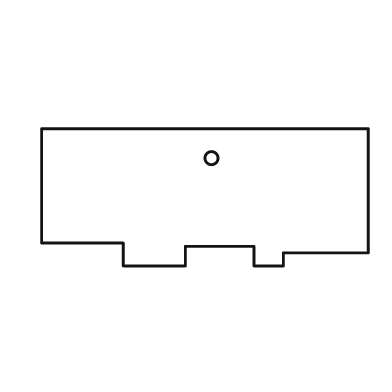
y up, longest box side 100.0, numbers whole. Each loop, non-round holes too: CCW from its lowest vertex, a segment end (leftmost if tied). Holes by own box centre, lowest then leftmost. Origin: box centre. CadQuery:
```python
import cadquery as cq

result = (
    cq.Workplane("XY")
    .moveTo(-25.0, -21.0)
    .lineTo(-6.0, -21.0)
    .lineTo(-6.0, -15.0)
    .lineTo(15.0, -15.0)
    .lineTo(15.0, -21.0)
    .lineTo(24.0, -21.0)
    .lineTo(24.0, -17.0)
    .lineTo(50.0, -17.0)
    .lineTo(50.0, 21.0)
    .lineTo(-50.0, 21.0)
    .lineTo(-50.0, -14.0)
    .lineTo(-25.0, -14.0)
    .close()
    .moveTo(2.0, 12.0)
    .circle(2.0)
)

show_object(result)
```